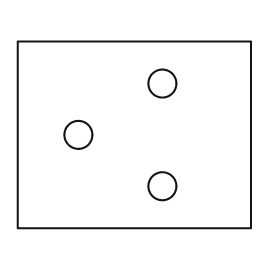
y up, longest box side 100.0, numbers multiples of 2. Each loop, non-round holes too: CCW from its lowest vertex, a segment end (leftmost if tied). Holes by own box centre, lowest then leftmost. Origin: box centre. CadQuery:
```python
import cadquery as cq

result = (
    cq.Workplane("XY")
    .moveTo(-50.0, -40.0)
    .lineTo(50.0, -40.0)
    .lineTo(50.0, 40.0)
    .lineTo(-50.0, 40.0)
    .close()
    .moveTo(12.0, -22.0)
    .circle(6.0)
    .moveTo(-24.0, 0.0)
    .circle(6.0)
    .moveTo(12.0, 22.0)
    .circle(6.0)
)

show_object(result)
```